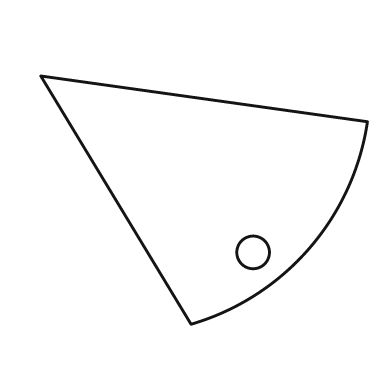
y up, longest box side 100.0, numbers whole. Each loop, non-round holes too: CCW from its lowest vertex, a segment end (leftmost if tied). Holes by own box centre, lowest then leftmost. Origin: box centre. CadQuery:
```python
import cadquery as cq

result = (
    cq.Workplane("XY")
    .moveTo(-4.0, -38.0)
    .threePointArc((32.0, -15.0), (50.0, 24.0))
    .lineTo(-50.0, 38.0)
    .close()
    .moveTo(15.0, -16.0)
    .circle(5.0)
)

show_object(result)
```